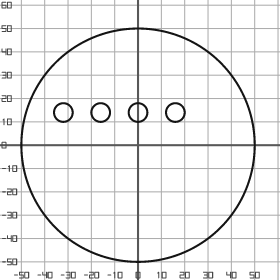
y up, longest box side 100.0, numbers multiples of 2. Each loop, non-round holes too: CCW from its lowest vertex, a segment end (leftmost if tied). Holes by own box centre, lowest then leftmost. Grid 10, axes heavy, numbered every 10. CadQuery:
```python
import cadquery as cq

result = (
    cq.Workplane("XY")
    .moveTo(0.0, 0.0)
    .circle(50.0)
    .moveTo(-32.0, 14.0)
    .circle(4.0)
    .moveTo(-16.0, 14.0)
    .circle(4.0)
    .moveTo(0.0, 14.0)
    .circle(4.0)
    .moveTo(16.0, 14.0)
    .circle(4.0)
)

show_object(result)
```